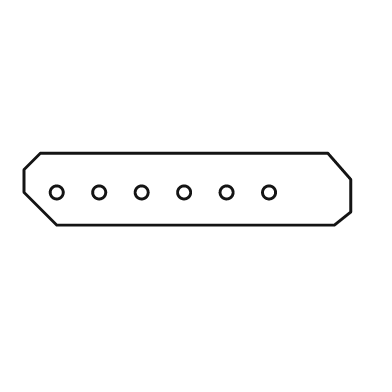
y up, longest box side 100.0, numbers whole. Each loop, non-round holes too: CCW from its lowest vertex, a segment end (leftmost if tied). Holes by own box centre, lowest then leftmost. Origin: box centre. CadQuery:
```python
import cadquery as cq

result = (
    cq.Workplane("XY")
    .moveTo(-40.0, -11.0)
    .lineTo(45.0, -11.0)
    .lineTo(50.0, -7.0)
    .lineTo(50.0, 3.0)
    .lineTo(43.0, 11.0)
    .lineTo(-45.0, 11.0)
    .lineTo(-50.0, 6.0)
    .lineTo(-50.0, -1.0)
    .close()
    .moveTo(-40.0, -1.0)
    .circle(2.0)
    .moveTo(-27.0, -1.0)
    .circle(2.0)
    .moveTo(-14.0, -1.0)
    .circle(2.0)
    .moveTo(-1.0, -1.0)
    .circle(2.0)
    .moveTo(12.0, -1.0)
    .circle(2.0)
    .moveTo(25.0, -1.0)
    .circle(2.0)
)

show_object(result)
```